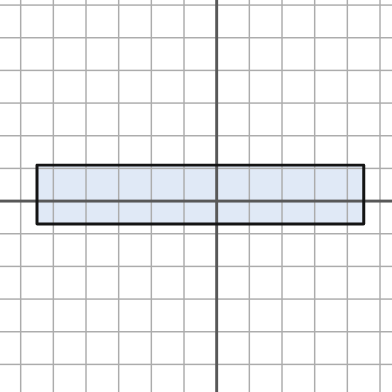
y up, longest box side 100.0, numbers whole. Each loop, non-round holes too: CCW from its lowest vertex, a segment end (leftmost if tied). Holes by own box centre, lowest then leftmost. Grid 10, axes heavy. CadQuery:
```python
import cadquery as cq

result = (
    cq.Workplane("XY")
    .moveTo(-55.0, -7.0)
    .lineTo(45.0, -7.0)
    .lineTo(45.0, 11.0)
    .lineTo(-55.0, 11.0)
    .close()
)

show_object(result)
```